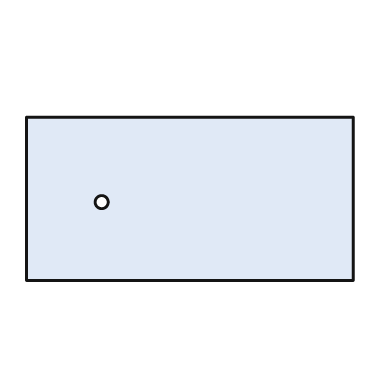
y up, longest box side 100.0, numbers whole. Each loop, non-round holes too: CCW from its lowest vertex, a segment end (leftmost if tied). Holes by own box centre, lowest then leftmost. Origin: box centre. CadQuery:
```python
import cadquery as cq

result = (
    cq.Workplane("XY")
    .moveTo(-50.0, -25.0)
    .lineTo(50.0, -25.0)
    .lineTo(50.0, 25.0)
    .lineTo(-50.0, 25.0)
    .close()
    .moveTo(-27.0, -1.0)
    .circle(2.0)
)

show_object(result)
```